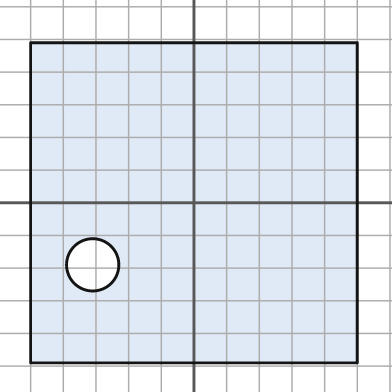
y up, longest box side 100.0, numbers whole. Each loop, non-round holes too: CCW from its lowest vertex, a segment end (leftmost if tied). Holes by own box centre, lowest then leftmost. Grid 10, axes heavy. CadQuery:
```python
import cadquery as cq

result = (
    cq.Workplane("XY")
    .moveTo(-50.0, -49.0)
    .lineTo(50.0, -49.0)
    .lineTo(50.0, 49.0)
    .lineTo(-50.0, 49.0)
    .close()
    .moveTo(-31.0, -19.0)
    .circle(8.0)
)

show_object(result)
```